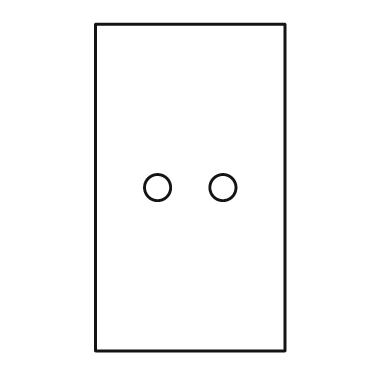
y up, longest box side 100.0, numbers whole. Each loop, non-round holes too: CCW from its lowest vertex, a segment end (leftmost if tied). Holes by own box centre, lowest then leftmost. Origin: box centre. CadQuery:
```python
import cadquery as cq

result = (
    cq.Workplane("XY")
    .moveTo(-29.0, -50.0)
    .lineTo(29.0, -50.0)
    .lineTo(29.0, 50.0)
    .lineTo(-29.0, 50.0)
    .close()
    .moveTo(-10.0, 0.0)
    .circle(4.0)
    .moveTo(10.0, 0.0)
    .circle(4.0)
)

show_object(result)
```